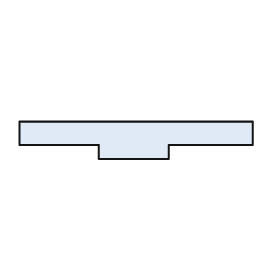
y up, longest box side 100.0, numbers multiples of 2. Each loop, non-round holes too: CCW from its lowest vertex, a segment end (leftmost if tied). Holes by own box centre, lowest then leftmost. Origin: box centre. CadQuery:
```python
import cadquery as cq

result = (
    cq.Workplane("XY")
    .moveTo(-16.0, -8.0)
    .lineTo(14.0, -8.0)
    .lineTo(14.0, -2.0)
    .lineTo(50.0, -2.0)
    .lineTo(50.0, 8.0)
    .lineTo(-50.0, 8.0)
    .lineTo(-50.0, -2.0)
    .lineTo(-16.0, -2.0)
    .close()
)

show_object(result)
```